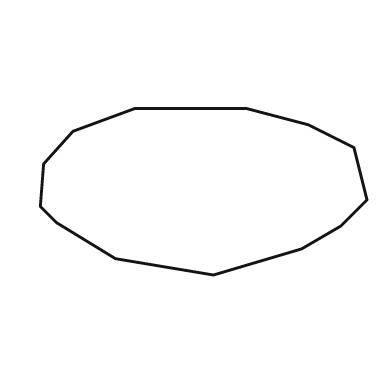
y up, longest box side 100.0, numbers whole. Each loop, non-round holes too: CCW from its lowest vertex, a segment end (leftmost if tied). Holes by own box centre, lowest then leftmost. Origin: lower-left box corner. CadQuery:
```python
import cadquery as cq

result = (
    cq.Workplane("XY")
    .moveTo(53.0, 0.0)
    .lineTo(80.0, 8.0)
    .lineTo(92.0, 15.0)
    .lineTo(100.0, 23.0)
    .lineTo(96.0, 39.0)
    .lineTo(82.0, 46.0)
    .lineTo(63.0, 51.0)
    .lineTo(29.0, 51.0)
    .lineTo(10.0, 44.0)
    .lineTo(1.0, 34.0)
    .lineTo(0.0, 21.0)
    .lineTo(5.0, 16.0)
    .lineTo(23.0, 5.0)
    .close()
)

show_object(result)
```